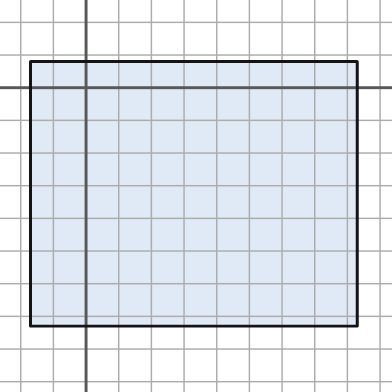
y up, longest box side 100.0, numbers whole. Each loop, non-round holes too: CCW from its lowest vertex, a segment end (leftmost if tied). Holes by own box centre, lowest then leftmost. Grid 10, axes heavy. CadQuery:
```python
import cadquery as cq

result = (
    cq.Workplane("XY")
    .moveTo(-17.0, -73.0)
    .lineTo(83.0, -73.0)
    .lineTo(83.0, 8.0)
    .lineTo(-17.0, 8.0)
    .close()
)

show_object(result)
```